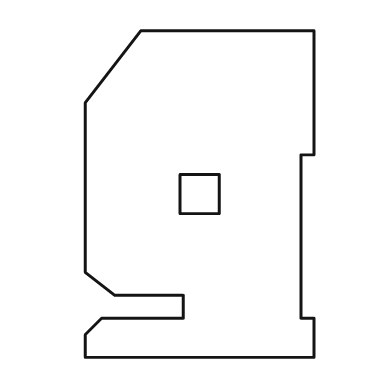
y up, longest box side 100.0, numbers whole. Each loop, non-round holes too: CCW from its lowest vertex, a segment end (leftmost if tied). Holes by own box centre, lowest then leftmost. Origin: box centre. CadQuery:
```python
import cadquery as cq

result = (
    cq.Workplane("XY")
    .moveTo(-35.0, -50.0)
    .lineTo(35.0, -50.0)
    .lineTo(35.0, -38.0)
    .lineTo(31.0, -38.0)
    .lineTo(31.0, 12.0)
    .lineTo(35.0, 12.0)
    .lineTo(35.0, 50.0)
    .lineTo(-18.0, 50.0)
    .lineTo(-35.0, 28.0)
    .lineTo(-35.0, -24.0)
    .lineTo(-26.0, -31.0)
    .lineTo(-5.0, -31.0)
    .lineTo(-5.0, -38.0)
    .lineTo(-30.0, -38.0)
    .lineTo(-35.0, -43.0)
    .close()
    .moveTo(-6.0, -6.0)
    .lineTo(6.0, -6.0)
    .lineTo(6.0, 6.0)
    .lineTo(-6.0, 6.0)
    .close()
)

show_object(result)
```